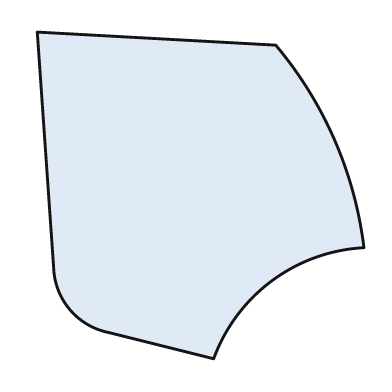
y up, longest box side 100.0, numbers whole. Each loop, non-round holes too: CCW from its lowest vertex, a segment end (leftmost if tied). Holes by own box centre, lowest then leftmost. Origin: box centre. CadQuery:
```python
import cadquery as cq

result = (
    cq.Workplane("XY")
    .moveTo(4.0, -50.0)
    .threePointArc((22.0, -26.0), (50.0, -16.0))
    .threePointArc((41.0, 17.0), (23.0, 46.0))
    .lineTo(-50.0, 50.0)
    .lineTo(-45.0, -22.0)
    .threePointArc((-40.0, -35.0), (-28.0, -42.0))
    .close()
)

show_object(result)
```